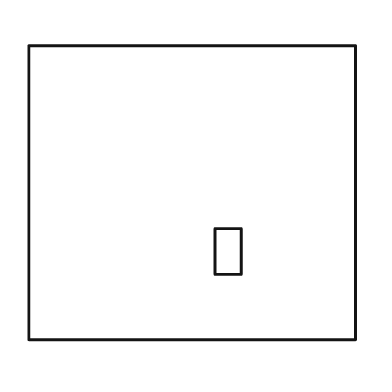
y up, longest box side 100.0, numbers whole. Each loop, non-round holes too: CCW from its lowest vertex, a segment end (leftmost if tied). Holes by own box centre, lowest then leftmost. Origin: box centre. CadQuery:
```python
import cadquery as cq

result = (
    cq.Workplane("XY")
    .moveTo(-50.0, -45.0)
    .lineTo(50.0, -45.0)
    .lineTo(50.0, 45.0)
    .lineTo(-50.0, 45.0)
    .close()
    .moveTo(7.0, -25.0)
    .lineTo(15.0, -25.0)
    .lineTo(15.0, -11.0)
    .lineTo(7.0, -11.0)
    .close()
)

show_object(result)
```